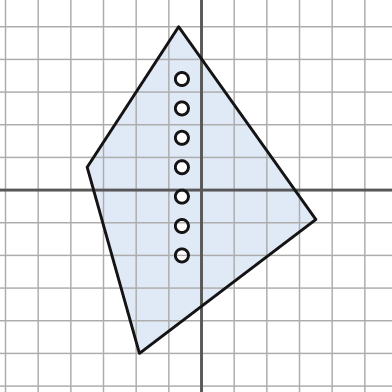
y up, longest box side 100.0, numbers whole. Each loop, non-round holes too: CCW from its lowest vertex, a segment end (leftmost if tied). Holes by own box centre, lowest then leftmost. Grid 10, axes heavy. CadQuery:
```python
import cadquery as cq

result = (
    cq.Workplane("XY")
    .moveTo(-19.0, -50.0)
    .lineTo(35.0, -9.0)
    .lineTo(-7.0, 50.0)
    .lineTo(-35.0, 7.0)
    .close()
    .moveTo(-6.0, -20.0)
    .circle(2.0)
    .moveTo(-6.0, -11.0)
    .circle(2.0)
    .moveTo(-6.0, -2.0)
    .circle(2.0)
    .moveTo(-6.0, 7.0)
    .circle(2.0)
    .moveTo(-6.0, 16.0)
    .circle(2.0)
    .moveTo(-6.0, 25.0)
    .circle(2.0)
    .moveTo(-6.0, 34.0)
    .circle(2.0)
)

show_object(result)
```